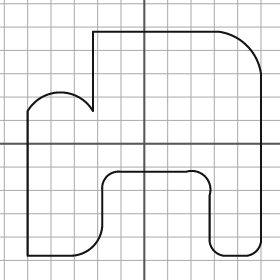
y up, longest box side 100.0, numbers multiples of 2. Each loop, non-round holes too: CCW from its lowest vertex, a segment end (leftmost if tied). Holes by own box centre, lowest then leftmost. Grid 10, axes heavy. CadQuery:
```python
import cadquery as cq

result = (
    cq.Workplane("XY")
    .moveTo(-50.0, -48.0)
    .lineTo(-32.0, -48.0)
    .threePointArc((-22.0, -44.0), (-18.0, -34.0))
    .lineTo(-18.0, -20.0)
    .threePointArc((-16.0, -14.0), (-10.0, -12.0))
    .lineTo(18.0, -12.0)
    .threePointArc((26.0, -14.0), (28.0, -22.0))
    .lineTo(28.0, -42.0)
    .threePointArc((30.0, -46.0), (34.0, -48.0))
    .lineTo(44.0, -48.0)
    .threePointArc((48.0, -46.0), (50.0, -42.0))
    .lineTo(50.0, 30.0)
    .threePointArc((44.0, 42.0), (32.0, 48.0))
    .lineTo(-22.0, 48.0)
    .lineTo(-22.0, 14.0)
    .threePointArc((-36.0, 22.0), (-50.0, 14.0))
    .close()
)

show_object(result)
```